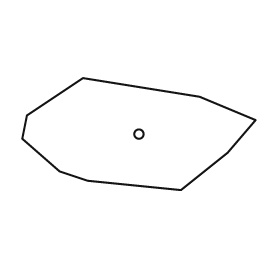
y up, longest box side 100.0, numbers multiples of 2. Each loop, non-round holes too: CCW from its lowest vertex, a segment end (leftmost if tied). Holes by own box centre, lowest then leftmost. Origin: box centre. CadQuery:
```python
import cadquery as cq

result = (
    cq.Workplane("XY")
    .moveTo(18.0, -24.0)
    .lineTo(38.0, -8.0)
    .lineTo(50.0, 6.0)
    .lineTo(26.0, 16.0)
    .lineTo(-24.0, 24.0)
    .lineTo(-48.0, 8.0)
    .lineTo(-50.0, -2.0)
    .lineTo(-34.0, -16.0)
    .lineTo(-22.0, -20.0)
    .close()
    .moveTo(0.0, 0.0)
    .circle(2.0)
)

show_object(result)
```